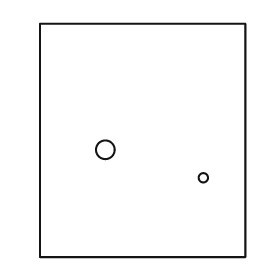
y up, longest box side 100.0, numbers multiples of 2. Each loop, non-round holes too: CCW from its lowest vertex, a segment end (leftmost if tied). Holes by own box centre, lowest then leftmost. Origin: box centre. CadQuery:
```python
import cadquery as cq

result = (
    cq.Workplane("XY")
    .moveTo(-44.0, -50.0)
    .lineTo(44.0, -50.0)
    .lineTo(44.0, 50.0)
    .lineTo(-44.0, 50.0)
    .close()
    .moveTo(26.0, -16.0)
    .circle(2.0)
    .moveTo(-16.0, -4.0)
    .circle(4.0)
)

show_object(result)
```